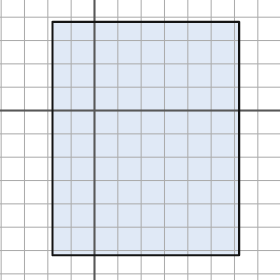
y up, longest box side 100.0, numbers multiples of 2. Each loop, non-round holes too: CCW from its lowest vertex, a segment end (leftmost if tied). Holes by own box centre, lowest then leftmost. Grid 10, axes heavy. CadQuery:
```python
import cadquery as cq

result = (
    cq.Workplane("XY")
    .moveTo(-18.0, -62.0)
    .lineTo(62.0, -62.0)
    .lineTo(62.0, 38.0)
    .lineTo(-18.0, 38.0)
    .close()
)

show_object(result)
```